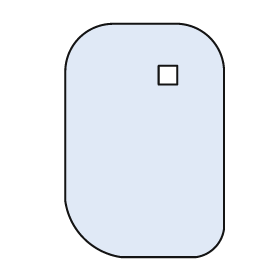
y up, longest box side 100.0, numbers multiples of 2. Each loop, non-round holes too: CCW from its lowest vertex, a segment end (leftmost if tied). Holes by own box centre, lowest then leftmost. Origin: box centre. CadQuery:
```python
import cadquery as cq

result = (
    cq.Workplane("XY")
    .moveTo(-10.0, -50.0)
    .lineTo(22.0, -50.0)
    .threePointArc((30.0, -46.0), (34.0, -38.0))
    .lineTo(34.0, 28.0)
    .threePointArc((28.0, 44.0), (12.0, 50.0))
    .lineTo(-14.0, 50.0)
    .threePointArc((-28.0, 44.0), (-34.0, 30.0))
    .lineTo(-34.0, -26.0)
    .threePointArc((-26.0, -42.0), (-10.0, -50.0))
    .close()
    .moveTo(6.0, 24.0)
    .lineTo(14.0, 24.0)
    .lineTo(14.0, 32.0)
    .lineTo(6.0, 32.0)
    .close()
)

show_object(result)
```